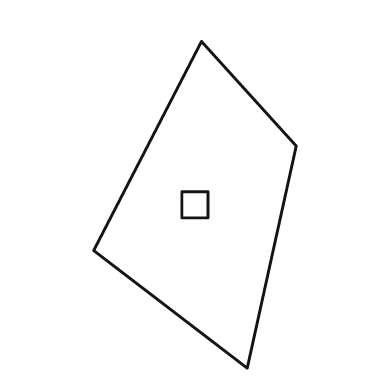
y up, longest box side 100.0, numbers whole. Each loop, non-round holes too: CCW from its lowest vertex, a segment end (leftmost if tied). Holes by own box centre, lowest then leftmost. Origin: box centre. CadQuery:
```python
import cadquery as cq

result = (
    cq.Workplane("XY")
    .moveTo(16.0, -50.0)
    .lineTo(31.0, 18.0)
    .lineTo(2.0, 50.0)
    .lineTo(-31.0, -14.0)
    .close()
    .moveTo(-4.0, -4.0)
    .lineTo(4.0, -4.0)
    .lineTo(4.0, 4.0)
    .lineTo(-4.0, 4.0)
    .close()
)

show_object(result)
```